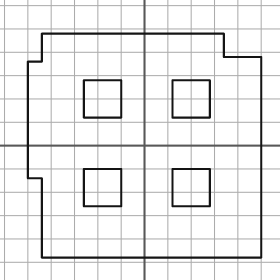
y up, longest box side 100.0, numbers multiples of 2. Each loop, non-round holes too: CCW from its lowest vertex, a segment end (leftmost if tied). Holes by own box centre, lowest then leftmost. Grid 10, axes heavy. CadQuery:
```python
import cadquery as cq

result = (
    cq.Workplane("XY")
    .moveTo(-44.0, -48.0)
    .lineTo(50.0, -48.0)
    .lineTo(50.0, 38.0)
    .lineTo(34.0, 38.0)
    .lineTo(34.0, 48.0)
    .lineTo(-44.0, 48.0)
    .lineTo(-44.0, 36.0)
    .lineTo(-50.0, 36.0)
    .lineTo(-50.0, -14.0)
    .lineTo(-44.0, -14.0)
    .close()
    .moveTo(-26.0, -26.0)
    .lineTo(-10.0, -26.0)
    .lineTo(-10.0, -10.0)
    .lineTo(-26.0, -10.0)
    .close()
    .moveTo(12.0, -26.0)
    .lineTo(28.0, -26.0)
    .lineTo(28.0, -10.0)
    .lineTo(12.0, -10.0)
    .close()
    .moveTo(-26.0, 12.0)
    .lineTo(-10.0, 12.0)
    .lineTo(-10.0, 28.0)
    .lineTo(-26.0, 28.0)
    .close()
    .moveTo(12.0, 12.0)
    .lineTo(28.0, 12.0)
    .lineTo(28.0, 28.0)
    .lineTo(12.0, 28.0)
    .close()
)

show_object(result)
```